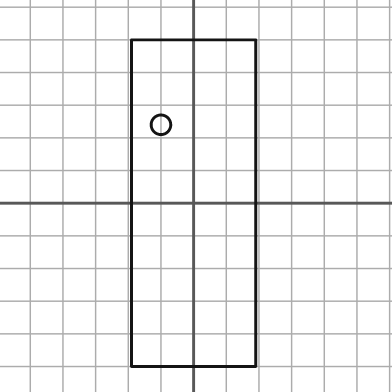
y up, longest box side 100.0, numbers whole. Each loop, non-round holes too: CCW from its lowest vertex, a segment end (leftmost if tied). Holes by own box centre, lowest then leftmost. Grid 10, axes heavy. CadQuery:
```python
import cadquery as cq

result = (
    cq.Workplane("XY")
    .moveTo(-19.0, -50.0)
    .lineTo(19.0, -50.0)
    .lineTo(19.0, 50.0)
    .lineTo(-19.0, 50.0)
    .close()
    .moveTo(-10.0, 24.0)
    .circle(3.0)
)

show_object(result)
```